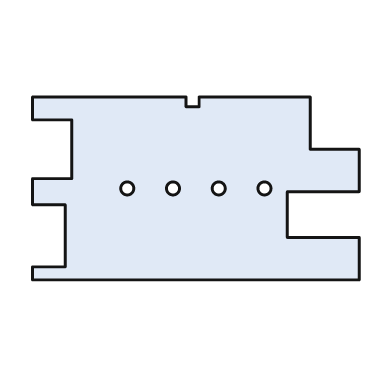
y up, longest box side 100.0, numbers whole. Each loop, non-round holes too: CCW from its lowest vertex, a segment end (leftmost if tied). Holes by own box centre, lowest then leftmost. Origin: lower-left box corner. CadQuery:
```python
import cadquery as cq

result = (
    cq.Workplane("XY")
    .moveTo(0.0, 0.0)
    .lineTo(100.0, 0.0)
    .lineTo(100.0, 13.0)
    .lineTo(78.0, 13.0)
    .lineTo(78.0, 27.0)
    .lineTo(100.0, 27.0)
    .lineTo(100.0, 40.0)
    .lineTo(85.0, 40.0)
    .lineTo(85.0, 56.0)
    .lineTo(51.0, 56.0)
    .lineTo(51.0, 53.0)
    .lineTo(47.0, 53.0)
    .lineTo(47.0, 56.0)
    .lineTo(0.0, 56.0)
    .lineTo(0.0, 49.0)
    .lineTo(12.0, 49.0)
    .lineTo(12.0, 31.0)
    .lineTo(0.0, 31.0)
    .lineTo(0.0, 23.0)
    .lineTo(10.0, 23.0)
    .lineTo(10.0, 4.0)
    .lineTo(0.0, 4.0)
    .close()
    .moveTo(29.0, 28.0)
    .circle(2.0)
    .moveTo(43.0, 28.0)
    .circle(2.0)
    .moveTo(57.0, 28.0)
    .circle(2.0)
    .moveTo(71.0, 28.0)
    .circle(2.0)
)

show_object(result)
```